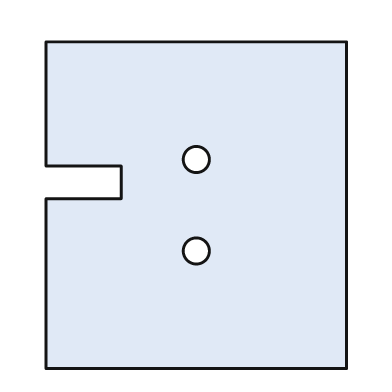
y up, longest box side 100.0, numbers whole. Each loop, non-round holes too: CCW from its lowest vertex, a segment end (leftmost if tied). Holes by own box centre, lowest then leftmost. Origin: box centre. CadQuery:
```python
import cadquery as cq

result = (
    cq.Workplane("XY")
    .moveTo(-46.0, -50.0)
    .lineTo(46.0, -50.0)
    .lineTo(46.0, 50.0)
    .lineTo(-46.0, 50.0)
    .lineTo(-46.0, 12.0)
    .lineTo(-23.0, 12.0)
    .lineTo(-23.0, 2.0)
    .lineTo(-46.0, 2.0)
    .close()
    .moveTo(0.0, -14.0)
    .circle(4.0)
    .moveTo(0.0, 14.0)
    .circle(4.0)
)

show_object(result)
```